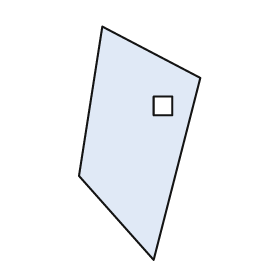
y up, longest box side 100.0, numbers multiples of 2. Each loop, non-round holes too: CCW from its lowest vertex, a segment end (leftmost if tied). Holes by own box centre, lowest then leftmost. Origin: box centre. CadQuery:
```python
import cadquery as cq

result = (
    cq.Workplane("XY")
    .moveTo(6.0, -50.0)
    .lineTo(26.0, 28.0)
    .lineTo(-16.0, 50.0)
    .lineTo(-26.0, -14.0)
    .close()
    .moveTo(6.0, 12.0)
    .lineTo(14.0, 12.0)
    .lineTo(14.0, 20.0)
    .lineTo(6.0, 20.0)
    .close()
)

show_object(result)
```